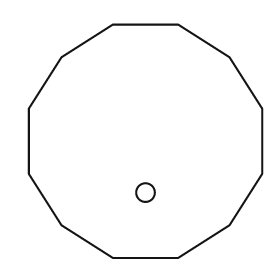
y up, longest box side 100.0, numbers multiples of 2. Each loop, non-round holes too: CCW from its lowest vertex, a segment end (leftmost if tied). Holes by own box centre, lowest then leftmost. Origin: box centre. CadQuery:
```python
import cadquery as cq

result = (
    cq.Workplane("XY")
    .moveTo(-14.0, -50.0)
    .lineTo(14.0, -50.0)
    .lineTo(36.0, -36.0)
    .lineTo(50.0, -14.0)
    .lineTo(50.0, 14.0)
    .lineTo(36.0, 36.0)
    .lineTo(14.0, 50.0)
    .lineTo(-14.0, 50.0)
    .lineTo(-36.0, 36.0)
    .lineTo(-50.0, 14.0)
    .lineTo(-50.0, -14.0)
    .lineTo(-36.0, -36.0)
    .close()
    .moveTo(0.0, -22.0)
    .circle(4.0)
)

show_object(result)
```